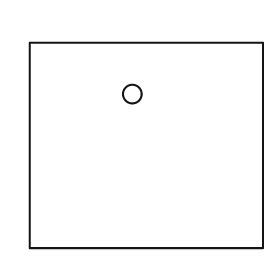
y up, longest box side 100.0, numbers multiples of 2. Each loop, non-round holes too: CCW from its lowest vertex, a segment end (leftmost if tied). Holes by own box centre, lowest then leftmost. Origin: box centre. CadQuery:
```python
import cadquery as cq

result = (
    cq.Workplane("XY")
    .moveTo(-50.0, -44.0)
    .lineTo(50.0, -44.0)
    .lineTo(50.0, 44.0)
    .lineTo(-50.0, 44.0)
    .close()
    .moveTo(-6.0, 22.0)
    .circle(4.0)
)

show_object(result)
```